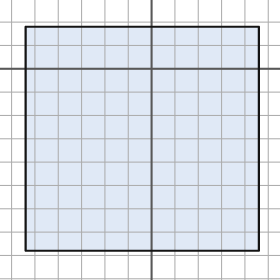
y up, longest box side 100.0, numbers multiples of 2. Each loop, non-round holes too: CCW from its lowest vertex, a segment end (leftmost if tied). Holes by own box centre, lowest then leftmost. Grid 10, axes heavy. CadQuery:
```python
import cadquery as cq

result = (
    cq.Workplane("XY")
    .moveTo(-54.0, -78.0)
    .lineTo(46.0, -78.0)
    .lineTo(46.0, 18.0)
    .lineTo(-54.0, 18.0)
    .close()
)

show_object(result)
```